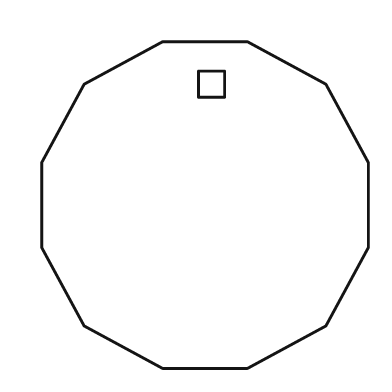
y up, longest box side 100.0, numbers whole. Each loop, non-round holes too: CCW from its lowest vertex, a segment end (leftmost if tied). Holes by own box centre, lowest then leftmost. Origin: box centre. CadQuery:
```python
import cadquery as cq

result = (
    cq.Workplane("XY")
    .moveTo(-13.0, -50.0)
    .lineTo(13.0, -50.0)
    .lineTo(37.0, -37.0)
    .lineTo(50.0, -13.0)
    .lineTo(50.0, 13.0)
    .lineTo(37.0, 37.0)
    .lineTo(13.0, 50.0)
    .lineTo(-13.0, 50.0)
    .lineTo(-37.0, 37.0)
    .lineTo(-50.0, 13.0)
    .lineTo(-50.0, -13.0)
    .lineTo(-37.0, -37.0)
    .close()
    .moveTo(-2.0, 33.0)
    .lineTo(6.0, 33.0)
    .lineTo(6.0, 41.0)
    .lineTo(-2.0, 41.0)
    .close()
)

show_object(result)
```